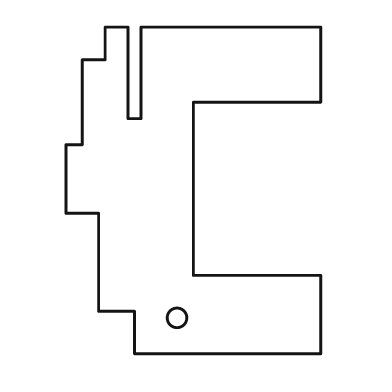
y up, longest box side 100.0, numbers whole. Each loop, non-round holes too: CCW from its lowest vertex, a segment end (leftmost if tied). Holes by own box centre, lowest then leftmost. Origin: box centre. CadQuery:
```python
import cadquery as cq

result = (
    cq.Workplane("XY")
    .moveTo(-18.0, -50.0)
    .lineTo(39.0, -50.0)
    .lineTo(39.0, -26.0)
    .lineTo(0.0, -26.0)
    .lineTo(0.0, 27.0)
    .lineTo(39.0, 27.0)
    .lineTo(39.0, 50.0)
    .lineTo(-16.0, 50.0)
    .lineTo(-16.0, 22.0)
    .lineTo(-20.0, 22.0)
    .lineTo(-20.0, 50.0)
    .lineTo(-27.0, 50.0)
    .lineTo(-27.0, 40.0)
    .lineTo(-34.0, 40.0)
    .lineTo(-34.0, 14.0)
    .lineTo(-39.0, 14.0)
    .lineTo(-39.0, -7.0)
    .lineTo(-29.0, -7.0)
    .lineTo(-29.0, -37.0)
    .lineTo(-18.0, -37.0)
    .close()
    .moveTo(-5.0, -39.0)
    .circle(3.0)
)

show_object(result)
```